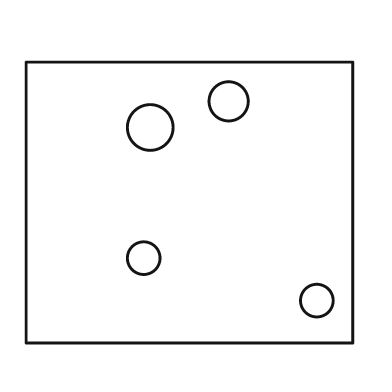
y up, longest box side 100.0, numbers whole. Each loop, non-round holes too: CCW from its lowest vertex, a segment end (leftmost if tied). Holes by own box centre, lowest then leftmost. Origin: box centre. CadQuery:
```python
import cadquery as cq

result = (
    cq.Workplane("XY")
    .moveTo(-50.0, -43.0)
    .lineTo(50.0, -43.0)
    .lineTo(50.0, 43.0)
    .lineTo(-50.0, 43.0)
    .close()
    .moveTo(39.0, -30.0)
    .circle(5.0)
    .moveTo(-14.0, -17.0)
    .circle(5.0)
    .moveTo(-12.0, 23.0)
    .circle(7.0)
    .moveTo(12.0, 31.0)
    .circle(6.0)
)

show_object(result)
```